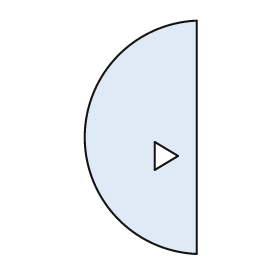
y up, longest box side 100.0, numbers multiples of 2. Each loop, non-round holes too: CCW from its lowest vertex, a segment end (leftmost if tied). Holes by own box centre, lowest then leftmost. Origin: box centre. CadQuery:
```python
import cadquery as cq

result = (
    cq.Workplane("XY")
    .moveTo(24.0, -50.0)
    .lineTo(24.0, 50.0)
    .threePointArc((-24.0, 0.0), (24.0, -50.0))
    .close()
    .moveTo(6.0, -14.0)
    .lineTo(16.0, -8.0)
    .lineTo(6.0, -2.0)
    .close()
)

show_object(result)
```